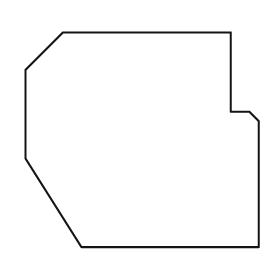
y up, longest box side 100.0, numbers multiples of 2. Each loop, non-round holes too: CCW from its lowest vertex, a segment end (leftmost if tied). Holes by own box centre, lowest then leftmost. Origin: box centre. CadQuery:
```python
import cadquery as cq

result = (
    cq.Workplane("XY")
    .moveTo(-26.0, -46.0)
    .lineTo(50.0, -46.0)
    .lineTo(50.0, 8.0)
    .lineTo(46.0, 12.0)
    .lineTo(38.0, 12.0)
    .lineTo(38.0, 46.0)
    .lineTo(-34.0, 46.0)
    .lineTo(-50.0, 30.0)
    .lineTo(-50.0, -8.0)
    .close()
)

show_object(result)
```